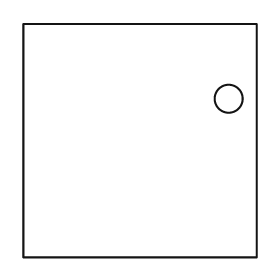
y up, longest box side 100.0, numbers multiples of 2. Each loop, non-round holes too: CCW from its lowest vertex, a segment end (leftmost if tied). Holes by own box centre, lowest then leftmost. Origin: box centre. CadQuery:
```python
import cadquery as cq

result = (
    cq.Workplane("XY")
    .moveTo(-50.0, -50.0)
    .lineTo(50.0, -50.0)
    .lineTo(50.0, 50.0)
    .lineTo(-50.0, 50.0)
    .close()
    .moveTo(38.0, 18.0)
    .circle(6.0)
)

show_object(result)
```